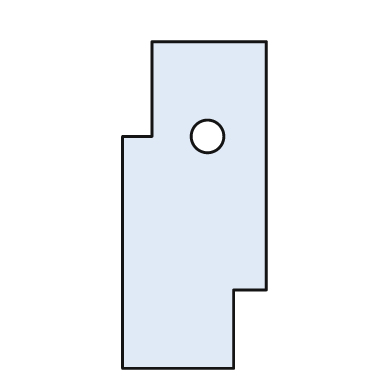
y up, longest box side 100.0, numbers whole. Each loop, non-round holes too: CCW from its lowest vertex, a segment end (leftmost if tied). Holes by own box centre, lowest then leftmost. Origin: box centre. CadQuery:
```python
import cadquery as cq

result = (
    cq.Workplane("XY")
    .moveTo(-22.0, -50.0)
    .lineTo(12.0, -50.0)
    .lineTo(12.0, -26.0)
    .lineTo(22.0, -26.0)
    .lineTo(22.0, 50.0)
    .lineTo(-13.0, 50.0)
    .lineTo(-13.0, 21.0)
    .lineTo(-22.0, 21.0)
    .close()
    .moveTo(4.0, 21.0)
    .circle(5.0)
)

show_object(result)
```